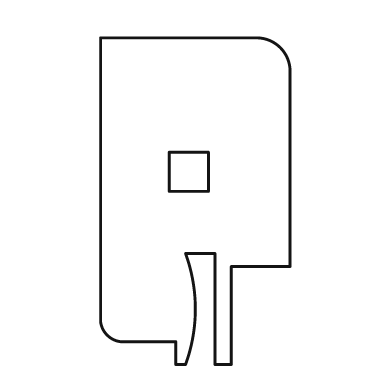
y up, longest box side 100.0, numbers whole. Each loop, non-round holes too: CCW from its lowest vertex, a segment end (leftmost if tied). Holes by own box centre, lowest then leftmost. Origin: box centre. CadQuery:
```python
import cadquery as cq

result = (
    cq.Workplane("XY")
    .moveTo(-6.0, -50.0)
    .lineTo(-3.0, -50.0)
    .threePointArc((0.0, -33.0), (-3.0, -16.0))
    .lineTo(6.0, -16.0)
    .lineTo(6.0, -50.0)
    .lineTo(11.0, -50.0)
    .lineTo(11.0, -20.0)
    .lineTo(29.0, -20.0)
    .lineTo(29.0, 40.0)
    .threePointArc((26.0, 47.0), (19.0, 50.0))
    .lineTo(-29.0, 50.0)
    .lineTo(-29.0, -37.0)
    .threePointArc((-27.0, -41.0), (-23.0, -43.0))
    .lineTo(-6.0, -43.0)
    .close()
    .moveTo(-8.0, 3.0)
    .lineTo(4.0, 3.0)
    .lineTo(4.0, 15.0)
    .lineTo(-8.0, 15.0)
    .close()
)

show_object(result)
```